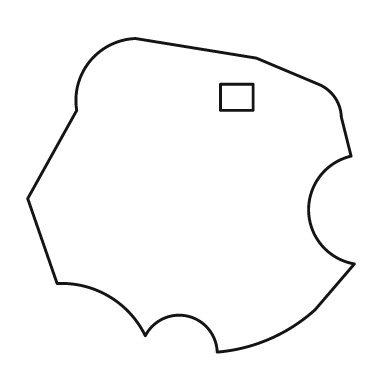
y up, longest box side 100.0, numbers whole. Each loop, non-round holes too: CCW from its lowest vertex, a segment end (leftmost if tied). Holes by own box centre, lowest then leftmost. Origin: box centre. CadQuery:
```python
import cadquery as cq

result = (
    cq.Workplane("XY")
    .moveTo(8.0, -48.0)
    .threePointArc((24.0, -44.0), (38.0, -35.0))
    .lineTo(50.0, -21.0)
    .threePointArc((36.0, -5.0), (49.0, 12.0))
    .lineTo(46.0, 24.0)
    .threePointArc((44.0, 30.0), (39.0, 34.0))
    .lineTo(20.0, 42.0)
    .lineTo(-17.0, 48.0)
    .threePointArc((-31.0, 41.0), (-35.0, 26.0))
    .lineTo(-50.0, -1.0)
    .lineTo(-41.0, -27.0)
    .threePointArc((-25.0, -31.0), (-14.0, -43.0))
    .threePointArc((-1.0, -37.0), (8.0, -48.0))
    .close()
    .moveTo(9.0, 26.0)
    .lineTo(19.0, 26.0)
    .lineTo(19.0, 34.0)
    .lineTo(9.0, 34.0)
    .close()
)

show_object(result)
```